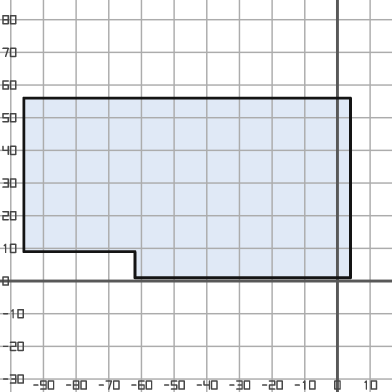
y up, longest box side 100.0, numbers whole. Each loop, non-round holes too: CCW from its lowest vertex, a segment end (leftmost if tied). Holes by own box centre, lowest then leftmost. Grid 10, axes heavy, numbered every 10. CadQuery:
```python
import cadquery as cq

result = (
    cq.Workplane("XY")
    .moveTo(-62.0, 1.0)
    .lineTo(4.0, 1.0)
    .lineTo(4.0, 56.0)
    .lineTo(-96.0, 56.0)
    .lineTo(-96.0, 9.0)
    .lineTo(-62.0, 9.0)
    .close()
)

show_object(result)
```